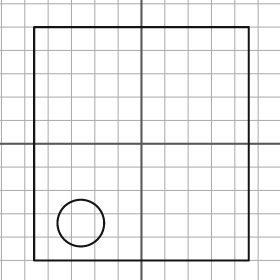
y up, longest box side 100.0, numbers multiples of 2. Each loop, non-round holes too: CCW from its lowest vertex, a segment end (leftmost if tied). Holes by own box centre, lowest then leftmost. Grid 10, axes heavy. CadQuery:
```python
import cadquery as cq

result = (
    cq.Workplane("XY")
    .moveTo(-46.0, -50.0)
    .lineTo(46.0, -50.0)
    .lineTo(46.0, 50.0)
    .lineTo(-46.0, 50.0)
    .close()
    .moveTo(-26.0, -34.0)
    .circle(10.0)
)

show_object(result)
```